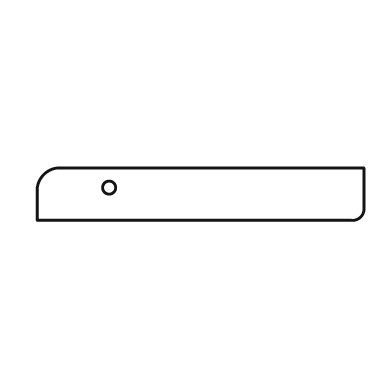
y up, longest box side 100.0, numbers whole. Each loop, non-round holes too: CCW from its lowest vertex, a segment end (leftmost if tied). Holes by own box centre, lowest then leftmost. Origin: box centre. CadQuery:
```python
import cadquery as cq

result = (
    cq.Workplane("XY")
    .moveTo(-50.0, -8.0)
    .lineTo(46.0, -8.0)
    .threePointArc((49.0, -7.0), (50.0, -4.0))
    .lineTo(50.0, 8.0)
    .lineTo(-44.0, 8.0)
    .threePointArc((-48.0, 6.0), (-50.0, 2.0))
    .close()
    .moveTo(-28.0, 2.0)
    .circle(2.0)
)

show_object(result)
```